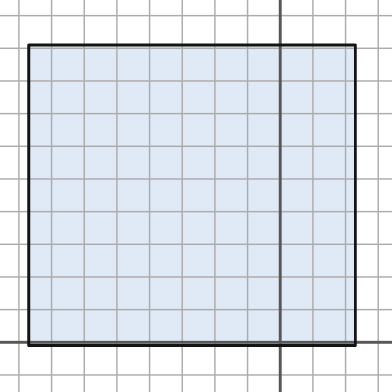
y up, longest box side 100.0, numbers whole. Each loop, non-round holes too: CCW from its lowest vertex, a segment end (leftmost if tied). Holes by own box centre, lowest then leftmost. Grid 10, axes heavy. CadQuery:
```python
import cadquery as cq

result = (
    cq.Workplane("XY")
    .moveTo(-77.0, -1.0)
    .lineTo(23.0, -1.0)
    .lineTo(23.0, 91.0)
    .lineTo(-77.0, 91.0)
    .close()
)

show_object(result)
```